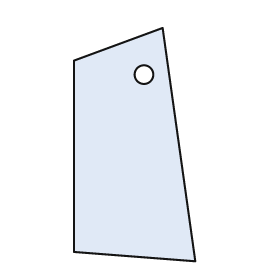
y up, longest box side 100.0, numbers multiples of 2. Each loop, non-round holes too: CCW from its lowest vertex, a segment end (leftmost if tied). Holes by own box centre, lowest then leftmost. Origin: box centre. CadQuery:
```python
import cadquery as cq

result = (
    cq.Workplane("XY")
    .moveTo(26.0, -50.0)
    .lineTo(12.0, 50.0)
    .lineTo(-26.0, 36.0)
    .lineTo(-26.0, -46.0)
    .close()
    .moveTo(4.0, 30.0)
    .circle(4.0)
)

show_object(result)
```